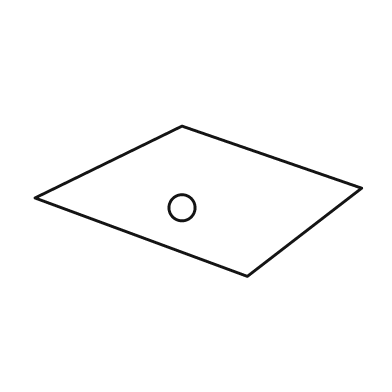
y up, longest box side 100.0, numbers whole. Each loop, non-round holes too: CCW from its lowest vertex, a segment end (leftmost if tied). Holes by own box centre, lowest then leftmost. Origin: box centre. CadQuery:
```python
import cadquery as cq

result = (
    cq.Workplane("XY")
    .moveTo(15.0, -23.0)
    .lineTo(50.0, 4.0)
    .lineTo(-5.0, 23.0)
    .lineTo(-50.0, 1.0)
    .close()
    .moveTo(-5.0, -2.0)
    .circle(4.0)
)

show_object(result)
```